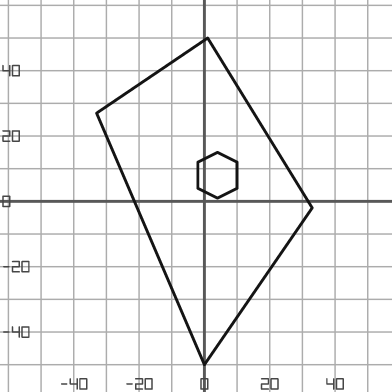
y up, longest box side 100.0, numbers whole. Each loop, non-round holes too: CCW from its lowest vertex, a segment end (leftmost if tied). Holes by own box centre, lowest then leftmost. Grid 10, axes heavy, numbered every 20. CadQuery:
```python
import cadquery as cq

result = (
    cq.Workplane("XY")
    .moveTo(0.0, -50.0)
    .lineTo(33.0, -2.0)
    .lineTo(1.0, 50.0)
    .lineTo(-33.0, 27.0)
    .close()
    .moveTo(4.0, 1.0)
    .lineTo(10.0, 4.0)
    .lineTo(10.0, 12.0)
    .lineTo(4.0, 15.0)
    .lineTo(-2.0, 12.0)
    .lineTo(-2.0, 4.0)
    .close()
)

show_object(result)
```